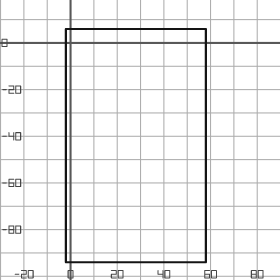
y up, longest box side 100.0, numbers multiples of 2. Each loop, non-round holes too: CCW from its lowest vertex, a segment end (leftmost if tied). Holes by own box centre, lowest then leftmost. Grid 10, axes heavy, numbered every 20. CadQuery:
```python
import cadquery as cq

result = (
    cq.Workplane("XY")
    .moveTo(-2.0, -94.0)
    .lineTo(58.0, -94.0)
    .lineTo(58.0, 6.0)
    .lineTo(-2.0, 6.0)
    .close()
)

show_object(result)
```